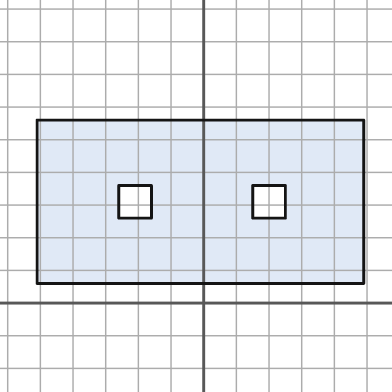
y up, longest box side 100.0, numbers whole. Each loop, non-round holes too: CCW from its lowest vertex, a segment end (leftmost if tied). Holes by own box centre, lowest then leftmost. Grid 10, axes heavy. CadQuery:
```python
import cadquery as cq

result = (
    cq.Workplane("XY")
    .moveTo(-51.0, 6.0)
    .lineTo(49.0, 6.0)
    .lineTo(49.0, 56.0)
    .lineTo(-51.0, 56.0)
    .close()
    .moveTo(-26.0, 26.0)
    .lineTo(-16.0, 26.0)
    .lineTo(-16.0, 36.0)
    .lineTo(-26.0, 36.0)
    .close()
    .moveTo(15.0, 26.0)
    .lineTo(25.0, 26.0)
    .lineTo(25.0, 36.0)
    .lineTo(15.0, 36.0)
    .close()
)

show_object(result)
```